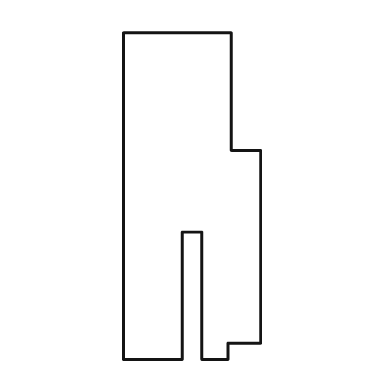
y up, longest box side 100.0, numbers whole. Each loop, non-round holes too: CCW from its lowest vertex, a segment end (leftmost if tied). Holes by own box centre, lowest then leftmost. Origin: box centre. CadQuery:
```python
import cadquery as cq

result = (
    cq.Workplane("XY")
    .moveTo(-21.0, -50.0)
    .lineTo(-3.0, -50.0)
    .lineTo(-3.0, -11.0)
    .lineTo(3.0, -11.0)
    .lineTo(3.0, -50.0)
    .lineTo(11.0, -50.0)
    .lineTo(11.0, -45.0)
    .lineTo(21.0, -45.0)
    .lineTo(21.0, 14.0)
    .lineTo(12.0, 14.0)
    .lineTo(12.0, 50.0)
    .lineTo(-21.0, 50.0)
    .close()
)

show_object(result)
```